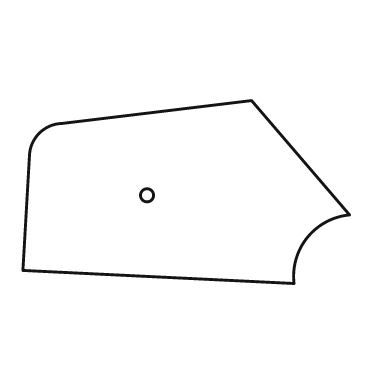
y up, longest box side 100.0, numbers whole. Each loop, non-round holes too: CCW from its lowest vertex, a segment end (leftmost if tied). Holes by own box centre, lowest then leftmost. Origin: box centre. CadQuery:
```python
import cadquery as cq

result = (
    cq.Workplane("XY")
    .moveTo(33.0, -28.0)
    .threePointArc((37.0, -14.0), (50.0, -7.0))
    .lineTo(20.0, 28.0)
    .lineTo(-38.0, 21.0)
    .threePointArc((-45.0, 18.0), (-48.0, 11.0))
    .lineTo(-50.0, -24.0)
    .close()
    .moveTo(-12.0, -1.0)
    .circle(2.0)
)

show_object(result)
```